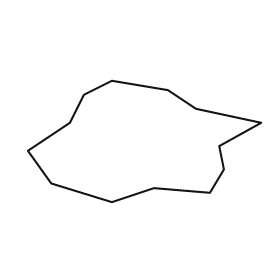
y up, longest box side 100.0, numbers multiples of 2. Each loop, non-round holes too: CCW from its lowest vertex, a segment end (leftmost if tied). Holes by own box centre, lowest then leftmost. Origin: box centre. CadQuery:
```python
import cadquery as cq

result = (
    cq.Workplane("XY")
    .moveTo(-14.0, -26.0)
    .lineTo(4.0, -20.0)
    .lineTo(28.0, -22.0)
    .lineTo(34.0, -12.0)
    .lineTo(32.0, -2.0)
    .lineTo(50.0, 8.0)
    .lineTo(22.0, 14.0)
    .lineTo(10.0, 22.0)
    .lineTo(-14.0, 26.0)
    .lineTo(-26.0, 20.0)
    .lineTo(-32.0, 8.0)
    .lineTo(-50.0, -4.0)
    .lineTo(-40.0, -18.0)
    .close()
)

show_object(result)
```